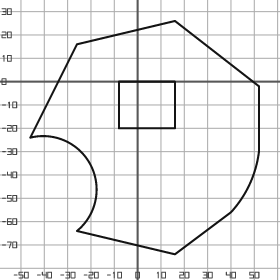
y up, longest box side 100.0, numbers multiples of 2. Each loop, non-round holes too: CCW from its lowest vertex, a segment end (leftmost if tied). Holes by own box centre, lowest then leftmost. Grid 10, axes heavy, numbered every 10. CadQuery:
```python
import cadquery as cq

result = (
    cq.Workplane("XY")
    .moveTo(16.0, -74.0)
    .lineTo(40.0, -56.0)
    .threePointArc((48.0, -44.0), (52.0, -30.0))
    .lineTo(52.0, -2.0)
    .lineTo(16.0, 26.0)
    .lineTo(-26.0, 16.0)
    .lineTo(-46.0, -24.0)
    .threePointArc((-20.0, -36.0), (-26.0, -64.0))
    .close()
    .moveTo(-8.0, -20.0)
    .lineTo(16.0, -20.0)
    .lineTo(16.0, 0.0)
    .lineTo(-8.0, 0.0)
    .close()
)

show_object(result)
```